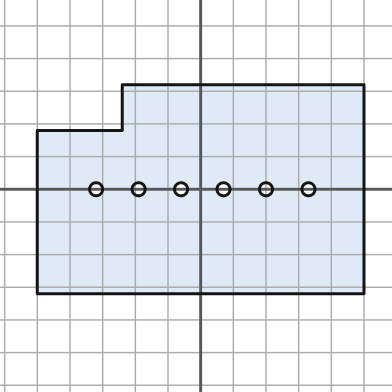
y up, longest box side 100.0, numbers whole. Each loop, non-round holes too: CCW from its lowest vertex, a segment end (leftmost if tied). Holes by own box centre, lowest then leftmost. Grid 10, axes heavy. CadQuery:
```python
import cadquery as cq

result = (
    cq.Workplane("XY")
    .moveTo(-50.0, -32.0)
    .lineTo(50.0, -32.0)
    .lineTo(50.0, 32.0)
    .lineTo(-24.0, 32.0)
    .lineTo(-24.0, 18.0)
    .lineTo(-50.0, 18.0)
    .close()
    .moveTo(-32.0, 0.0)
    .circle(2.0)
    .moveTo(-19.0, 0.0)
    .circle(2.0)
    .moveTo(-6.0, 0.0)
    .circle(2.0)
    .moveTo(7.0, 0.0)
    .circle(2.0)
    .moveTo(20.0, 0.0)
    .circle(2.0)
    .moveTo(33.0, 0.0)
    .circle(2.0)
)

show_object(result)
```